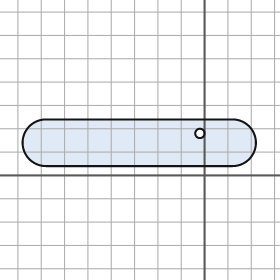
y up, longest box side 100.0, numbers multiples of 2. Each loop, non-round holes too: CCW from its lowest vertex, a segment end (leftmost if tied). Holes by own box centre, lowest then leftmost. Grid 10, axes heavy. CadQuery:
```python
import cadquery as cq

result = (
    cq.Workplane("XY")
    .moveTo(-68.0, 4.0)
    .lineTo(12.0, 4.0)
    .threePointArc((22.0, 14.0), (12.0, 24.0))
    .lineTo(-68.0, 24.0)
    .threePointArc((-78.0, 14.0), (-68.0, 4.0))
    .close()
    .moveTo(-2.0, 18.0)
    .circle(2.0)
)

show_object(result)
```